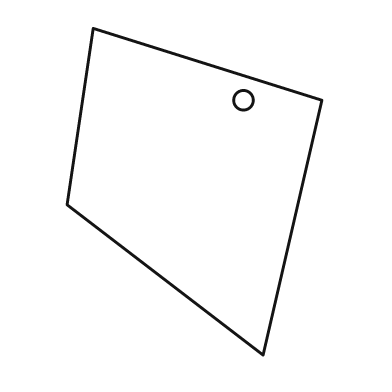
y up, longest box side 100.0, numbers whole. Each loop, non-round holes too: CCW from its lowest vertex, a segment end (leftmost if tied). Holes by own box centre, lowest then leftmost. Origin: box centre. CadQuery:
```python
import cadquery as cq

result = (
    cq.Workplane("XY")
    .moveTo(21.0, -50.0)
    .lineTo(39.0, 28.0)
    .lineTo(-31.0, 50.0)
    .lineTo(-39.0, -4.0)
    .close()
    .moveTo(15.0, 28.0)
    .circle(3.0)
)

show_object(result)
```